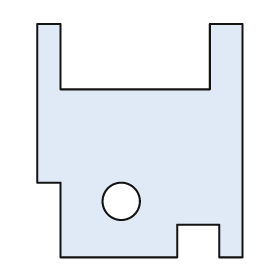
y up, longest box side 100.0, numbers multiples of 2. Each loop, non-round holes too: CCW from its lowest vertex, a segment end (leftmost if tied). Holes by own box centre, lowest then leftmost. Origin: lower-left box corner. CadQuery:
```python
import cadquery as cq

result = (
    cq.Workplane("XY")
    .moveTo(10.0, 0.0)
    .lineTo(60.0, 0.0)
    .lineTo(60.0, 14.0)
    .lineTo(78.0, 14.0)
    .lineTo(78.0, 0.0)
    .lineTo(88.0, 0.0)
    .lineTo(88.0, 100.0)
    .lineTo(74.0, 100.0)
    .lineTo(74.0, 72.0)
    .lineTo(10.0, 72.0)
    .lineTo(10.0, 100.0)
    .lineTo(0.0, 100.0)
    .lineTo(0.0, 32.0)
    .lineTo(10.0, 32.0)
    .close()
    .moveTo(36.0, 24.0)
    .circle(8.0)
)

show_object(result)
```